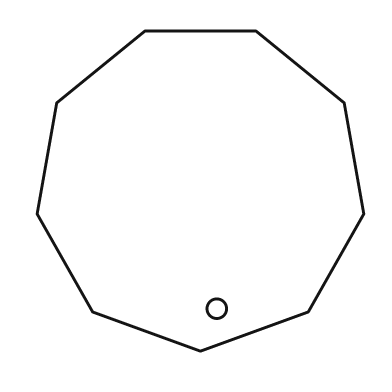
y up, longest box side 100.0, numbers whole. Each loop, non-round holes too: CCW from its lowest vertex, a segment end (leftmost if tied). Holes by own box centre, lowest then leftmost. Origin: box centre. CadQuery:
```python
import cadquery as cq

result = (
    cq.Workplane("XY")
    .moveTo(0.0, -49.0)
    .lineTo(33.0, -37.0)
    .lineTo(50.0, -7.0)
    .lineTo(44.0, 27.0)
    .lineTo(17.0, 49.0)
    .lineTo(-17.0, 49.0)
    .lineTo(-44.0, 27.0)
    .lineTo(-50.0, -7.0)
    .lineTo(-33.0, -37.0)
    .close()
    .moveTo(5.0, -36.0)
    .circle(3.0)
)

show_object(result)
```